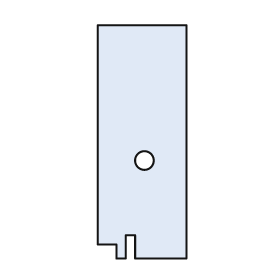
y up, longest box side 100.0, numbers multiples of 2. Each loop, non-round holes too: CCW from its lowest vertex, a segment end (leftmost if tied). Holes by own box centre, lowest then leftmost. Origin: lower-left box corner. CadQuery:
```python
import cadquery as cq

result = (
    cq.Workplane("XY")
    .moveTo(8.0, 0.0)
    .lineTo(12.0, 0.0)
    .lineTo(12.0, 10.0)
    .lineTo(16.0, 10.0)
    .lineTo(16.0, 0.0)
    .lineTo(38.0, 0.0)
    .lineTo(38.0, 100.0)
    .lineTo(0.0, 100.0)
    .lineTo(0.0, 6.0)
    .lineTo(8.0, 6.0)
    .close()
    .moveTo(20.0, 42.0)
    .circle(4.0)
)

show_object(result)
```